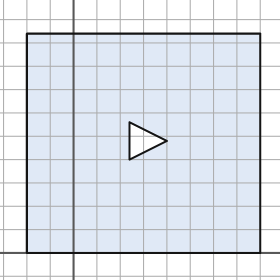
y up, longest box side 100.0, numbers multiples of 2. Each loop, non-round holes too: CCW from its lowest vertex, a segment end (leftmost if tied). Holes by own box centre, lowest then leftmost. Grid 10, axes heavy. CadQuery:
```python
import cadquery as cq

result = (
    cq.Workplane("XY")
    .moveTo(-20.0, 0.0)
    .lineTo(80.0, 0.0)
    .lineTo(80.0, 94.0)
    .lineTo(-20.0, 94.0)
    .close()
    .moveTo(24.0, 40.0)
    .lineTo(40.0, 48.0)
    .lineTo(24.0, 56.0)
    .close()
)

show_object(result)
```